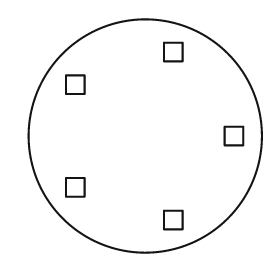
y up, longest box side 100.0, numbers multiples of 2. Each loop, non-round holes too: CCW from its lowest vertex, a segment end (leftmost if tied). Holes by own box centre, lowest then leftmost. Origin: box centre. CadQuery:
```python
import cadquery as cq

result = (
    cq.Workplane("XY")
    .moveTo(0.0, 0.0)
    .circle(50.0)
    .moveTo(8.0, -40.0)
    .lineTo(16.0, -40.0)
    .lineTo(16.0, -32.0)
    .lineTo(8.0, -32.0)
    .close()
    .moveTo(-34.0, -26.0)
    .lineTo(-26.0, -26.0)
    .lineTo(-26.0, -18.0)
    .lineTo(-34.0, -18.0)
    .close()
    .moveTo(34.0, -4.0)
    .lineTo(42.0, -4.0)
    .lineTo(42.0, 4.0)
    .lineTo(34.0, 4.0)
    .close()
    .moveTo(-34.0, 18.0)
    .lineTo(-26.0, 18.0)
    .lineTo(-26.0, 26.0)
    .lineTo(-34.0, 26.0)
    .close()
    .moveTo(8.0, 32.0)
    .lineTo(16.0, 32.0)
    .lineTo(16.0, 40.0)
    .lineTo(8.0, 40.0)
    .close()
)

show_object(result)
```